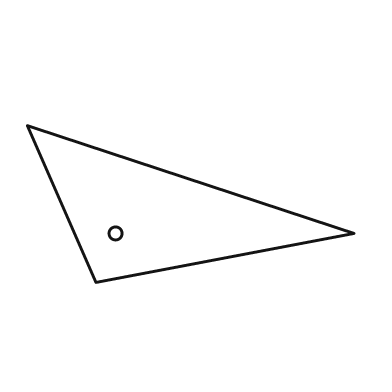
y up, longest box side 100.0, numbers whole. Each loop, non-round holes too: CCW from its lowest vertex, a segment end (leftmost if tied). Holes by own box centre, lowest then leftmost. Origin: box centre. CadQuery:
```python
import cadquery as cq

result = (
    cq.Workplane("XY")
    .moveTo(-29.0, -24.0)
    .lineTo(50.0, -9.0)
    .lineTo(-50.0, 24.0)
    .close()
    .moveTo(-23.0, -9.0)
    .circle(2.0)
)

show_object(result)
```